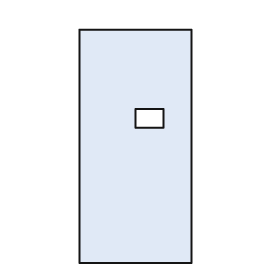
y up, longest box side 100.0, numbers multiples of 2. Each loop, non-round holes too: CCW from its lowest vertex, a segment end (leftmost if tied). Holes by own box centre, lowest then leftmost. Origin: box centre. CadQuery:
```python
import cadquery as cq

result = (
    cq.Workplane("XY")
    .moveTo(-24.0, -50.0)
    .lineTo(24.0, -50.0)
    .lineTo(24.0, 50.0)
    .lineTo(-24.0, 50.0)
    .close()
    .moveTo(0.0, 8.0)
    .lineTo(12.0, 8.0)
    .lineTo(12.0, 16.0)
    .lineTo(0.0, 16.0)
    .close()
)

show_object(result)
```